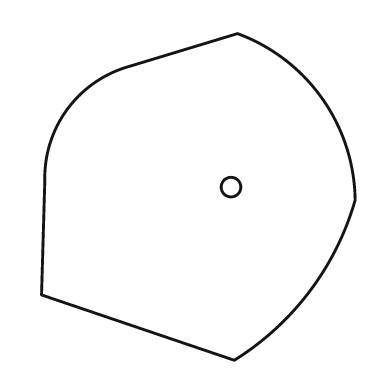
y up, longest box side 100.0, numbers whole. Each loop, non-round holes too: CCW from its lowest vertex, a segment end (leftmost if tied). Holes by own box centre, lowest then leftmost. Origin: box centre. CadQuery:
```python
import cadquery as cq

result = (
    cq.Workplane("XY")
    .moveTo(11.0, -50.0)
    .threePointArc((34.0, -29.0), (48.0, -1.0))
    .threePointArc((38.0, 30.0), (12.0, 50.0))
    .lineTo(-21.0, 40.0)
    .threePointArc((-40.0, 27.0), (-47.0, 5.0))
    .lineTo(-48.0, -30.0)
    .close()
    .moveTo(10.0, 3.0)
    .circle(3.0)
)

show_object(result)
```